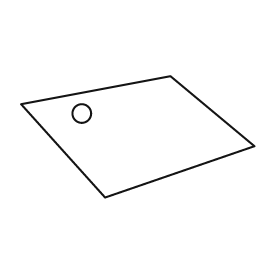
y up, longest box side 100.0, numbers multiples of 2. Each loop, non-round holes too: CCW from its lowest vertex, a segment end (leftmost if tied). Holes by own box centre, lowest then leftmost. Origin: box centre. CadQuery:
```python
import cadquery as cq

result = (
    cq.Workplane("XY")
    .moveTo(-14.0, -26.0)
    .lineTo(50.0, -4.0)
    .lineTo(14.0, 26.0)
    .lineTo(-50.0, 14.0)
    .close()
    .moveTo(-24.0, 10.0)
    .circle(4.0)
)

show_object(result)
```